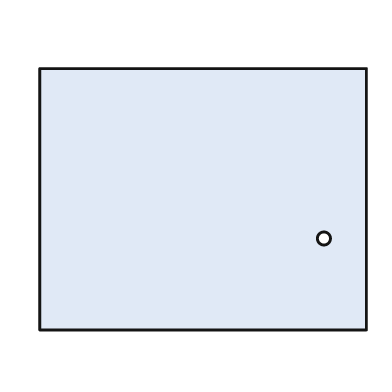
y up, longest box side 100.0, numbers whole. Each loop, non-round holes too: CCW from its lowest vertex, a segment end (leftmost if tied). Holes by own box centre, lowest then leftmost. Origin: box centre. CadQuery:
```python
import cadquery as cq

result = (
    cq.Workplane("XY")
    .moveTo(-50.0, -40.0)
    .lineTo(50.0, -40.0)
    .lineTo(50.0, 40.0)
    .lineTo(-50.0, 40.0)
    .close()
    .moveTo(37.0, -12.0)
    .circle(2.0)
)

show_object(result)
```